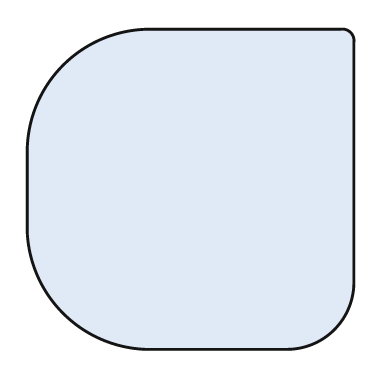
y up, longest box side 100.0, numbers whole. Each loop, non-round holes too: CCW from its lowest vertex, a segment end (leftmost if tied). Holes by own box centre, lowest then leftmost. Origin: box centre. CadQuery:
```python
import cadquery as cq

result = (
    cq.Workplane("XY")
    .moveTo(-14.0, -49.0)
    .lineTo(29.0, -49.0)
    .threePointArc((44.0, -43.0), (50.0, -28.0))
    .lineTo(50.0, 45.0)
    .threePointArc((49.0, 48.0), (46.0, 49.0))
    .lineTo(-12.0, 49.0)
    .threePointArc((-39.0, 38.0), (-50.0, 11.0))
    .lineTo(-50.0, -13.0)
    .threePointArc((-39.0, -38.0), (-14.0, -49.0))
    .close()
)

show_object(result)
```